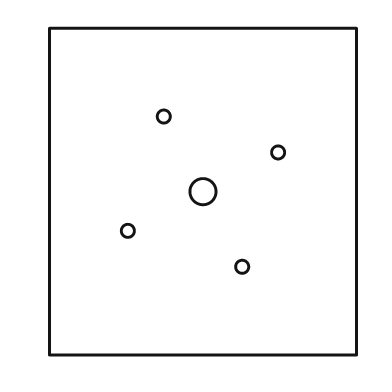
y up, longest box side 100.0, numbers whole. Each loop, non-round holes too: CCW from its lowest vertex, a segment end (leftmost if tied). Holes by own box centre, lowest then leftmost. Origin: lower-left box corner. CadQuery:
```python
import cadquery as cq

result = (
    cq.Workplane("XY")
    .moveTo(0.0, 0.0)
    .lineTo(94.0, 0.0)
    .lineTo(94.0, 100.0)
    .lineTo(0.0, 100.0)
    .close()
    .moveTo(59.0, 27.0)
    .circle(2.0)
    .moveTo(24.0, 38.0)
    .circle(2.0)
    .moveTo(47.0, 50.0)
    .circle(4.0)
    .moveTo(70.0, 62.0)
    .circle(2.0)
    .moveTo(35.0, 73.0)
    .circle(2.0)
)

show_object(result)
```